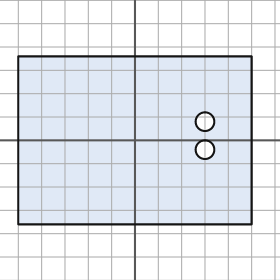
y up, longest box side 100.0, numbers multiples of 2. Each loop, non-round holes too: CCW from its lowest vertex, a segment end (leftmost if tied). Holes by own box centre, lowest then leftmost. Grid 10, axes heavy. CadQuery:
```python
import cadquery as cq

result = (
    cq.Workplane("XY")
    .moveTo(-50.0, -36.0)
    .lineTo(50.0, -36.0)
    .lineTo(50.0, 36.0)
    .lineTo(-50.0, 36.0)
    .close()
    .moveTo(30.0, -4.0)
    .circle(4.0)
    .moveTo(30.0, 8.0)
    .circle(4.0)
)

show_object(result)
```